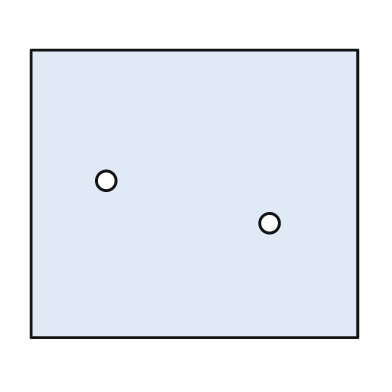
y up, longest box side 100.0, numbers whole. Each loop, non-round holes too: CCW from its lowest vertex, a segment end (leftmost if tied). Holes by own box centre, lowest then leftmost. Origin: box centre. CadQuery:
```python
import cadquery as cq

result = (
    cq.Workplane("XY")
    .moveTo(-50.0, -44.0)
    .lineTo(50.0, -44.0)
    .lineTo(50.0, 44.0)
    .lineTo(-50.0, 44.0)
    .close()
    .moveTo(23.0, -9.0)
    .circle(3.0)
    .moveTo(-27.0, 4.0)
    .circle(3.0)
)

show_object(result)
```